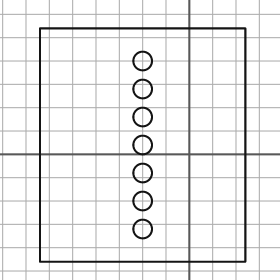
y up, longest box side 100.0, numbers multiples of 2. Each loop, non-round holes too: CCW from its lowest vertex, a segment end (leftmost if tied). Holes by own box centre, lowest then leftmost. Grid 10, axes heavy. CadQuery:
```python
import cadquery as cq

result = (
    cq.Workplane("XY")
    .moveTo(-64.0, -46.0)
    .lineTo(24.0, -46.0)
    .lineTo(24.0, 54.0)
    .lineTo(-64.0, 54.0)
    .close()
    .moveTo(-20.0, -32.0)
    .circle(4.0)
    .moveTo(-20.0, -20.0)
    .circle(4.0)
    .moveTo(-20.0, -8.0)
    .circle(4.0)
    .moveTo(-20.0, 4.0)
    .circle(4.0)
    .moveTo(-20.0, 16.0)
    .circle(4.0)
    .moveTo(-20.0, 28.0)
    .circle(4.0)
    .moveTo(-20.0, 40.0)
    .circle(4.0)
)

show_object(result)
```